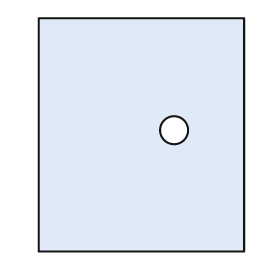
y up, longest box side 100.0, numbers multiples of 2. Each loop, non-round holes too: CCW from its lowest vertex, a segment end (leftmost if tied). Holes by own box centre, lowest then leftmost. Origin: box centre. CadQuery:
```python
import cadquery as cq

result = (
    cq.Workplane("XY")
    .moveTo(-44.0, -50.0)
    .lineTo(44.0, -50.0)
    .lineTo(44.0, 50.0)
    .lineTo(-44.0, 50.0)
    .close()
    .moveTo(14.0, 2.0)
    .circle(6.0)
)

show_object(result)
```